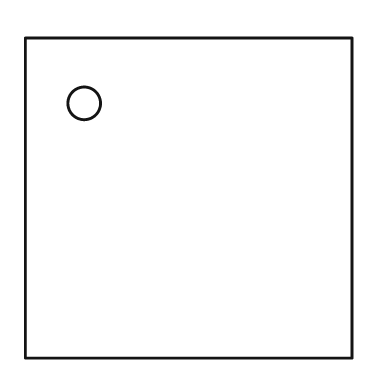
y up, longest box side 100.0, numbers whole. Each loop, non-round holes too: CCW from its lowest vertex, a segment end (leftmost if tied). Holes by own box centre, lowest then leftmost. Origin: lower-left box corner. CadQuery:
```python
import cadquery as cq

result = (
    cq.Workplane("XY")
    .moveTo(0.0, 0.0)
    .lineTo(100.0, 0.0)
    .lineTo(100.0, 98.0)
    .lineTo(0.0, 98.0)
    .close()
    .moveTo(18.0, 78.0)
    .circle(5.0)
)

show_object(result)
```